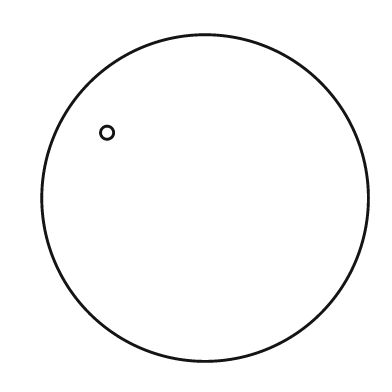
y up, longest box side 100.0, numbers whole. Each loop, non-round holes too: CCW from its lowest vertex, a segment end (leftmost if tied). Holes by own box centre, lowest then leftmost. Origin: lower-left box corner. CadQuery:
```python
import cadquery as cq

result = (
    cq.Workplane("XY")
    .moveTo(50.0, 50.0)
    .circle(50.0)
    .moveTo(20.0, 70.0)
    .circle(2.0)
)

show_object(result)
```